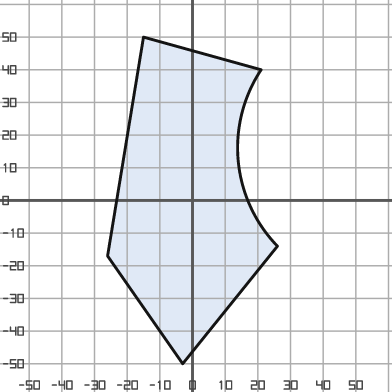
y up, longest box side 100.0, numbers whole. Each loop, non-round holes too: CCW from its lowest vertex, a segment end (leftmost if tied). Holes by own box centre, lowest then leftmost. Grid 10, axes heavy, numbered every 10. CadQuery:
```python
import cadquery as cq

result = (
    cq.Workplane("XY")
    .moveTo(-3.0, -50.0)
    .lineTo(26.0, -14.0)
    .threePointArc((14.0, 12.0), (21.0, 40.0))
    .lineTo(-15.0, 50.0)
    .lineTo(-26.0, -17.0)
    .close()
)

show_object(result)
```